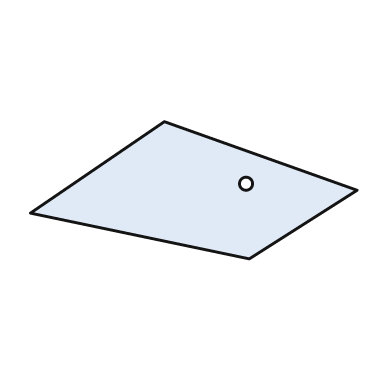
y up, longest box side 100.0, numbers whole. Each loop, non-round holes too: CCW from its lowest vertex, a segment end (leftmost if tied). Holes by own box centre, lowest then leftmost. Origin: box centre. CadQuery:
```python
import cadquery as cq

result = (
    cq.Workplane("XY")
    .moveTo(17.0, -21.0)
    .lineTo(50.0, 0.0)
    .lineTo(-9.0, 21.0)
    .lineTo(-50.0, -7.0)
    .close()
    .moveTo(16.0, 2.0)
    .circle(2.0)
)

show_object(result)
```